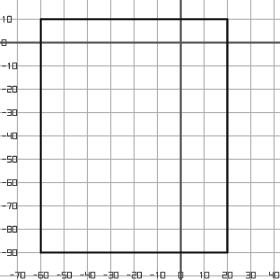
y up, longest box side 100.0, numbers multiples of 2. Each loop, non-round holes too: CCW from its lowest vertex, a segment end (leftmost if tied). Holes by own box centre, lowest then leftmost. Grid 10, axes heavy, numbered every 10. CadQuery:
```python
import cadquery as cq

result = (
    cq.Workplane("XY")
    .moveTo(-60.0, -90.0)
    .lineTo(20.0, -90.0)
    .lineTo(20.0, 10.0)
    .lineTo(-60.0, 10.0)
    .close()
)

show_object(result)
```